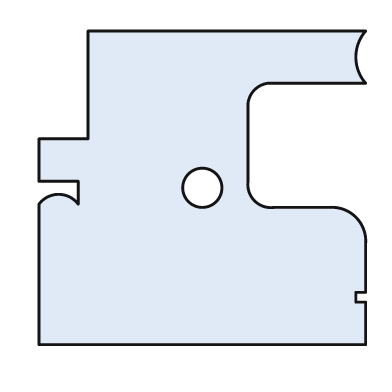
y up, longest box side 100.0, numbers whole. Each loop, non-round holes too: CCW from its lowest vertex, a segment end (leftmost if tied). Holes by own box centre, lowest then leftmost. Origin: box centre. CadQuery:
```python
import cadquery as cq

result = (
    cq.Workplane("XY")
    .moveTo(-50.0, -48.0)
    .lineTo(50.0, -48.0)
    .lineTo(50.0, -35.0)
    .lineTo(47.0, -35.0)
    .lineTo(47.0, -32.0)
    .lineTo(50.0, -32.0)
    .lineTo(50.0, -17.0)
    .threePointArc((47.0, -9.0), (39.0, -6.0))
    .lineTo(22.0, -6.0)
    .threePointArc((16.0, -4.0), (14.0, 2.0))
    .lineTo(14.0, 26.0)
    .threePointArc((16.0, 30.0), (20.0, 32.0))
    .lineTo(50.0, 32.0)
    .threePointArc((47.0, 40.0), (50.0, 48.0))
    .lineTo(-35.0, 48.0)
    .lineTo(-35.0, 15.0)
    .lineTo(-50.0, 15.0)
    .lineTo(-50.0, 2.0)
    .lineTo(-38.0, 2.0)
    .lineTo(-38.0, -5.0)
    .threePointArc((-44.0, -2.0), (-50.0, -5.0))
    .close()
    .moveTo(0.0, 0.0)
    .circle(6.0)
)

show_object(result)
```